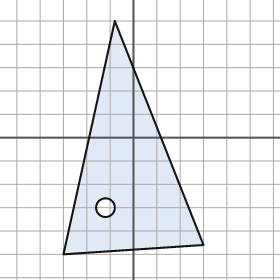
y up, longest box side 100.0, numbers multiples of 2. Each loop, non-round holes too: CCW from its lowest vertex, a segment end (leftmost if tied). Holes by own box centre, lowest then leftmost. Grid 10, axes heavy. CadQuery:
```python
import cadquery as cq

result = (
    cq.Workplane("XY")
    .moveTo(-30.0, -50.0)
    .lineTo(30.0, -46.0)
    .lineTo(-8.0, 50.0)
    .close()
    .moveTo(-12.0, -30.0)
    .circle(4.0)
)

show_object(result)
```